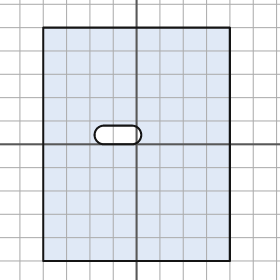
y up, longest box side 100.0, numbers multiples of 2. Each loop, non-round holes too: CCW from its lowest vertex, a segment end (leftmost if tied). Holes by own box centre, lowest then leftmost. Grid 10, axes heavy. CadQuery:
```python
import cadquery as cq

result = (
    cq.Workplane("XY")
    .moveTo(-40.0, -50.0)
    .lineTo(40.0, -50.0)
    .lineTo(40.0, 50.0)
    .lineTo(-40.0, 50.0)
    .close()
    .moveTo(-14.0, 0.0)
    .lineTo(-2.0, 0.0)
    .threePointArc((2.0, 4.0), (-2.0, 8.0))
    .lineTo(-14.0, 8.0)
    .threePointArc((-18.0, 4.0), (-14.0, 0.0))
    .close()
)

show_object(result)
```